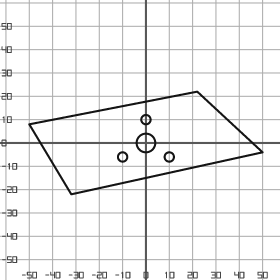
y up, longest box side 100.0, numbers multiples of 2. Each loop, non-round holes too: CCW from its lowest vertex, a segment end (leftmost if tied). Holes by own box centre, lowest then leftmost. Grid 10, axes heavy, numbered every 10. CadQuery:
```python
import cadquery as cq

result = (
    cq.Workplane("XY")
    .moveTo(-32.0, -22.0)
    .lineTo(50.0, -4.0)
    .lineTo(22.0, 22.0)
    .lineTo(-50.0, 8.0)
    .close()
    .moveTo(-10.0, -6.0)
    .circle(2.0)
    .moveTo(10.0, -6.0)
    .circle(2.0)
    .moveTo(0.0, 0.0)
    .circle(4.0)
    .moveTo(0.0, 10.0)
    .circle(2.0)
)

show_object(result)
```